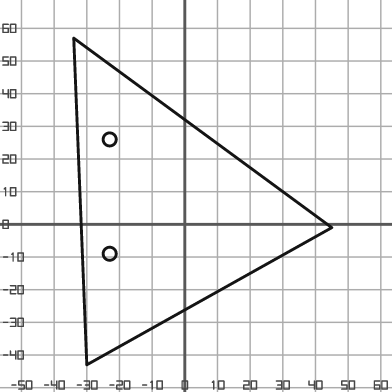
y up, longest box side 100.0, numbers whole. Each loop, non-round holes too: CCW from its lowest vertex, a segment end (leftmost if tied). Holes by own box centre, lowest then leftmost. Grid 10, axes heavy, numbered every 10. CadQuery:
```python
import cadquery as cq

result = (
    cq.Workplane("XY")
    .moveTo(-30.0, -43.0)
    .lineTo(45.0, -1.0)
    .lineTo(-34.0, 57.0)
    .close()
    .moveTo(-23.0, -9.0)
    .circle(2.0)
    .moveTo(-23.0, 26.0)
    .circle(2.0)
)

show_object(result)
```